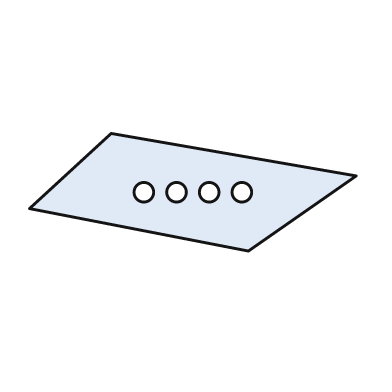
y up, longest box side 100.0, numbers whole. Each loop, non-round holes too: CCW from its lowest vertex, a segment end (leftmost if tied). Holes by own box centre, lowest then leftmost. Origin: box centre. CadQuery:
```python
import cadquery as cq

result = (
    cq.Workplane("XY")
    .moveTo(17.0, -18.0)
    .lineTo(50.0, 5.0)
    .lineTo(-25.0, 18.0)
    .lineTo(-50.0, -5.0)
    .close()
    .moveTo(-15.0, 0.0)
    .circle(3.0)
    .moveTo(-5.0, 0.0)
    .circle(3.0)
    .moveTo(5.0, 0.0)
    .circle(3.0)
    .moveTo(15.0, 0.0)
    .circle(3.0)
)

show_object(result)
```